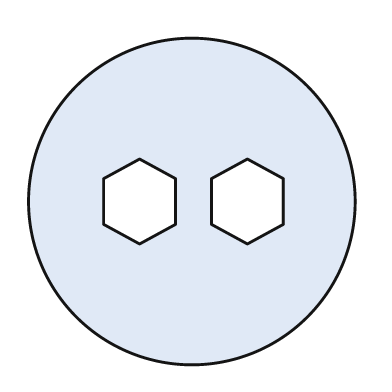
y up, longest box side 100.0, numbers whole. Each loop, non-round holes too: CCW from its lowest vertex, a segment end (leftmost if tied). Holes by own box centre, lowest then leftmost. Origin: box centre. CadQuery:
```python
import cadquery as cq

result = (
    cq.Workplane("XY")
    .moveTo(0.0, 0.0)
    .circle(50.0)
    .moveTo(-16.0, -13.0)
    .lineTo(-5.0, -7.0)
    .lineTo(-5.0, 7.0)
    .lineTo(-16.0, 13.0)
    .lineTo(-27.0, 7.0)
    .lineTo(-27.0, -7.0)
    .close()
    .moveTo(17.0, -13.0)
    .lineTo(28.0, -7.0)
    .lineTo(28.0, 7.0)
    .lineTo(17.0, 13.0)
    .lineTo(6.0, 7.0)
    .lineTo(6.0, -7.0)
    .close()
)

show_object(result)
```